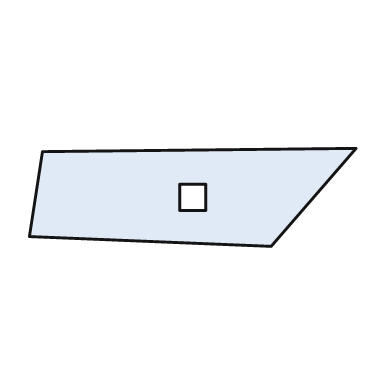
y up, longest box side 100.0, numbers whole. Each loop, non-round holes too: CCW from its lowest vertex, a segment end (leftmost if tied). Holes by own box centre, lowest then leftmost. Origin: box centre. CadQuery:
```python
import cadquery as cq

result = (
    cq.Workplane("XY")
    .moveTo(24.0, -15.0)
    .lineTo(50.0, 15.0)
    .lineTo(-46.0, 14.0)
    .lineTo(-50.0, -12.0)
    .close()
    .moveTo(-4.0, -4.0)
    .lineTo(4.0, -4.0)
    .lineTo(4.0, 4.0)
    .lineTo(-4.0, 4.0)
    .close()
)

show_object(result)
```